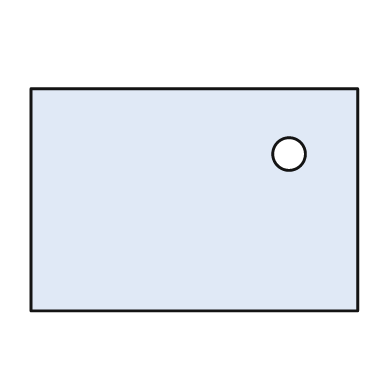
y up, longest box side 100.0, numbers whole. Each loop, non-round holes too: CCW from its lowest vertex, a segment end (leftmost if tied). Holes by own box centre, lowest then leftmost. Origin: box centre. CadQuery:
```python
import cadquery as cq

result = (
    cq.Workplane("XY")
    .moveTo(-50.0, -34.0)
    .lineTo(50.0, -34.0)
    .lineTo(50.0, 34.0)
    .lineTo(-50.0, 34.0)
    .close()
    .moveTo(29.0, 14.0)
    .circle(5.0)
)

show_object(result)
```